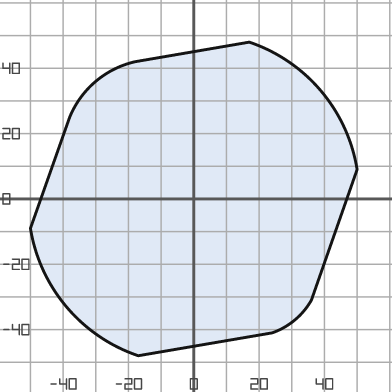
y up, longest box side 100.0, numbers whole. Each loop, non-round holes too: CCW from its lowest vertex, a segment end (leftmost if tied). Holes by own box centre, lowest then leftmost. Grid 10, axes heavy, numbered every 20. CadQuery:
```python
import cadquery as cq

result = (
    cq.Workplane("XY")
    .moveTo(-17.0, -48.0)
    .lineTo(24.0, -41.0)
    .threePointArc((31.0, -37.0), (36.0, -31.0))
    .lineTo(50.0, 9.0)
    .threePointArc((39.0, 33.0), (17.0, 48.0))
    .lineTo(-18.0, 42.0)
    .threePointArc((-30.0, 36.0), (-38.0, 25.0))
    .lineTo(-50.0, -9.0)
    .threePointArc((-39.0, -33.0), (-17.0, -48.0))
    .close()
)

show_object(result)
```